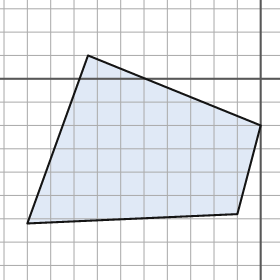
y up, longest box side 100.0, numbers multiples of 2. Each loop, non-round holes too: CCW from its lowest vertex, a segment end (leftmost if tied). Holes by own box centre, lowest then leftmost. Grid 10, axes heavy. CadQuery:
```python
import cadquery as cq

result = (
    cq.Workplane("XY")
    .moveTo(-100.0, -62.0)
    .lineTo(-10.0, -58.0)
    .lineTo(0.0, -20.0)
    .lineTo(-74.0, 10.0)
    .close()
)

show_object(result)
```